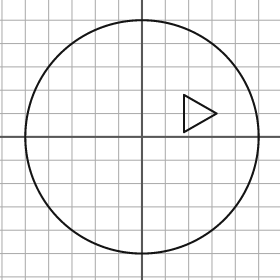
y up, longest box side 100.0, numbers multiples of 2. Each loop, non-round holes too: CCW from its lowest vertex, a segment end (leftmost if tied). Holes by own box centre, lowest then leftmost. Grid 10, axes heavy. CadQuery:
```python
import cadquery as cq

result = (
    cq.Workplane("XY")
    .moveTo(0.0, 0.0)
    .circle(50.0)
    .moveTo(18.0, 2.0)
    .lineTo(32.0, 10.0)
    .lineTo(18.0, 18.0)
    .close()
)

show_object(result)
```